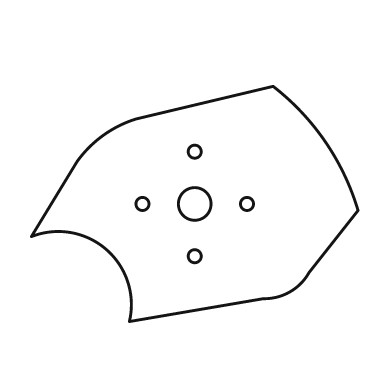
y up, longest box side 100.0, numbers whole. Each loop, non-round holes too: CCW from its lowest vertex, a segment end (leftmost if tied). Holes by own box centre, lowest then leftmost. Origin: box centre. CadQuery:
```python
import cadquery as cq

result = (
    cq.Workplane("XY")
    .moveTo(-20.0, -36.0)
    .lineTo(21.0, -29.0)
    .threePointArc((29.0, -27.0), (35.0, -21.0))
    .lineTo(50.0, -2.0)
    .threePointArc((40.0, 19.0), (24.0, 36.0))
    .lineTo(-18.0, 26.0)
    .threePointArc((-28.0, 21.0), (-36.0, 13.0))
    .lineTo(-50.0, -10.0)
    .threePointArc((-27.0, -14.0), (-20.0, -36.0))
    .close()
    .moveTo(0.0, -16.0)
    .circle(2.0)
    .moveTo(-16.0, 0.0)
    .circle(2.0)
    .moveTo(0.0, 0.0)
    .circle(5.0)
    .moveTo(16.0, 0.0)
    .circle(2.0)
    .moveTo(0.0, 16.0)
    .circle(2.0)
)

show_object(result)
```